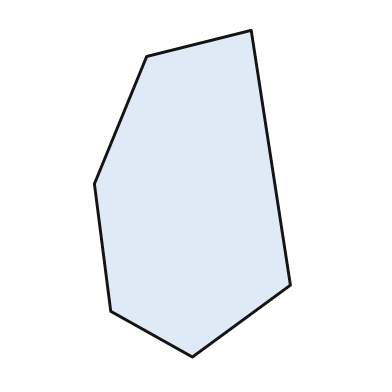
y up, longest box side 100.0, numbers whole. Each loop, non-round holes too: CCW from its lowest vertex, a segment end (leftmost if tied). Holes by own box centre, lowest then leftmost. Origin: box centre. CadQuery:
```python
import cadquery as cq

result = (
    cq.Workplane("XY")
    .moveTo(0.0, -50.0)
    .lineTo(30.0, -28.0)
    .lineTo(18.0, 50.0)
    .lineTo(-14.0, 42.0)
    .lineTo(-30.0, 3.0)
    .lineTo(-25.0, -36.0)
    .close()
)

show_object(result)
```